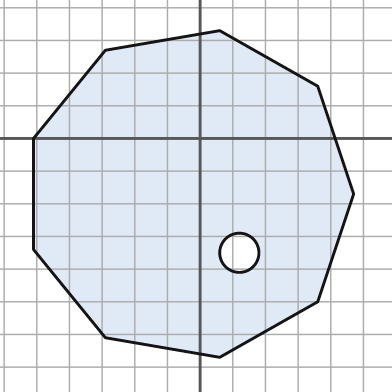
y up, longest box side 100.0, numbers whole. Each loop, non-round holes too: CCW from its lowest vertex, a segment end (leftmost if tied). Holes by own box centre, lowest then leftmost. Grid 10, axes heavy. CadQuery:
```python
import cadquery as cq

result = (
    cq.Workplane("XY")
    .moveTo(6.0, -67.0)
    .lineTo(36.0, -50.0)
    .lineTo(47.0, -17.0)
    .lineTo(36.0, 16.0)
    .lineTo(6.0, 33.0)
    .lineTo(-29.0, 27.0)
    .lineTo(-51.0, 0.0)
    .lineTo(-51.0, -34.0)
    .lineTo(-29.0, -61.0)
    .close()
    .moveTo(12.0, -35.0)
    .circle(6.0)
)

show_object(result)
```